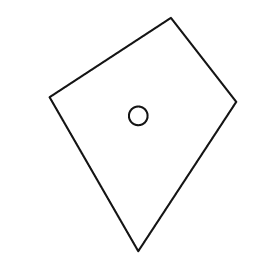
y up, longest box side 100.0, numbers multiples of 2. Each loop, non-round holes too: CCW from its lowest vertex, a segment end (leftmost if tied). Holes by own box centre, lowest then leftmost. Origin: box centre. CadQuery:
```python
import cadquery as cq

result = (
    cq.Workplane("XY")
    .moveTo(-2.0, -50.0)
    .lineTo(40.0, 14.0)
    .lineTo(12.0, 50.0)
    .lineTo(-40.0, 16.0)
    .close()
    .moveTo(-2.0, 8.0)
    .circle(4.0)
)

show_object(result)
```